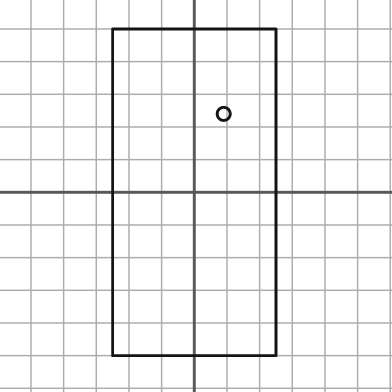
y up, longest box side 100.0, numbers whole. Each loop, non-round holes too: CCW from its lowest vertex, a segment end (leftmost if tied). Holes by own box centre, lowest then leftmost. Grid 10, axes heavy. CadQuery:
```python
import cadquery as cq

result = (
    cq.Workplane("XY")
    .moveTo(-25.0, -50.0)
    .lineTo(25.0, -50.0)
    .lineTo(25.0, 50.0)
    .lineTo(-25.0, 50.0)
    .close()
    .moveTo(9.0, 24.0)
    .circle(2.0)
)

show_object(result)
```